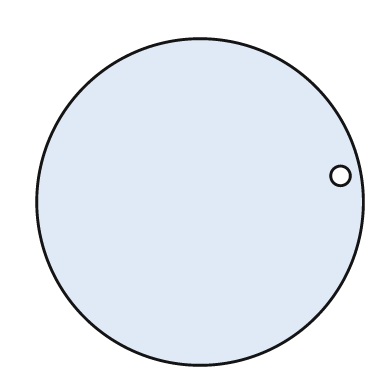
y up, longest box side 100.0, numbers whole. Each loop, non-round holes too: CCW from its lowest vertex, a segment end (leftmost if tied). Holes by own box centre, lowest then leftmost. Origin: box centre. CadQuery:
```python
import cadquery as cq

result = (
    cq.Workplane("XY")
    .moveTo(0.0, 0.0)
    .circle(50.0)
    .moveTo(43.0, 8.0)
    .circle(3.0)
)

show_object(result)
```